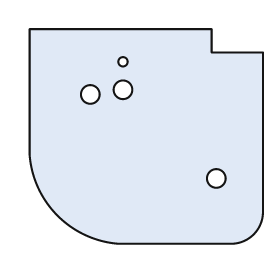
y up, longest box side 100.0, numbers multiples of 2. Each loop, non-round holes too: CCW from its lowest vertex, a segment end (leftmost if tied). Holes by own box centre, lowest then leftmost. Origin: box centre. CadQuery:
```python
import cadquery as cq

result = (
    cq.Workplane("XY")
    .moveTo(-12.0, -46.0)
    .lineTo(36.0, -46.0)
    .threePointArc((46.0, -42.0), (50.0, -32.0))
    .lineTo(50.0, 36.0)
    .lineTo(28.0, 36.0)
    .lineTo(28.0, 46.0)
    .lineTo(-50.0, 46.0)
    .lineTo(-50.0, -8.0)
    .threePointArc((-38.0, -34.0), (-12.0, -46.0))
    .close()
    .moveTo(30.0, -18.0)
    .circle(4.0)
    .moveTo(-24.0, 18.0)
    .circle(4.0)
    .moveTo(-10.0, 20.0)
    .circle(4.0)
    .moveTo(-10.0, 32.0)
    .circle(2.0)
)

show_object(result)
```